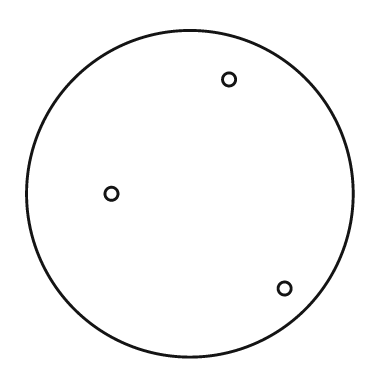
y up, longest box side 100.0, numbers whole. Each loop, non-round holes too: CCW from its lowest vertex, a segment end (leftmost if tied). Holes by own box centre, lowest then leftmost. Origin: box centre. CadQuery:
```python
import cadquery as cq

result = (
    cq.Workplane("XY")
    .moveTo(0.0, 0.0)
    .circle(50.0)
    .moveTo(29.0, -29.0)
    .circle(2.0)
    .moveTo(-24.0, 0.0)
    .circle(2.0)
    .moveTo(12.0, 35.0)
    .circle(2.0)
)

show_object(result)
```